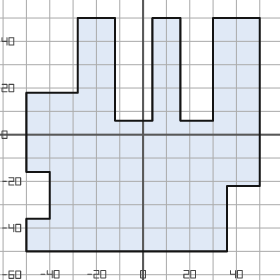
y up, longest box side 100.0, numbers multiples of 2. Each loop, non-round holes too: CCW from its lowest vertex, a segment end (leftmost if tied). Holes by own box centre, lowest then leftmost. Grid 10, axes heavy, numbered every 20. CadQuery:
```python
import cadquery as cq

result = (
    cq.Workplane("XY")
    .moveTo(-50.0, -50.0)
    .lineTo(36.0, -50.0)
    .lineTo(36.0, -22.0)
    .lineTo(50.0, -22.0)
    .lineTo(50.0, 50.0)
    .lineTo(30.0, 50.0)
    .lineTo(30.0, 6.0)
    .lineTo(16.0, 6.0)
    .lineTo(16.0, 50.0)
    .lineTo(4.0, 50.0)
    .lineTo(4.0, 6.0)
    .lineTo(-12.0, 6.0)
    .lineTo(-12.0, 50.0)
    .lineTo(-28.0, 50.0)
    .lineTo(-28.0, 18.0)
    .lineTo(-50.0, 18.0)
    .lineTo(-50.0, -16.0)
    .lineTo(-40.0, -16.0)
    .lineTo(-40.0, -36.0)
    .lineTo(-50.0, -36.0)
    .close()
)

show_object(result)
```